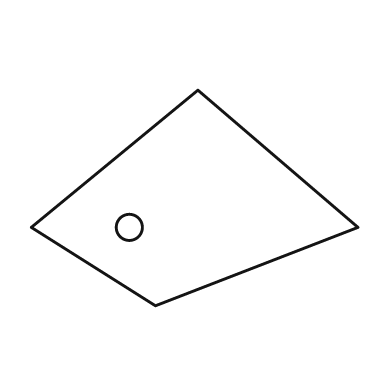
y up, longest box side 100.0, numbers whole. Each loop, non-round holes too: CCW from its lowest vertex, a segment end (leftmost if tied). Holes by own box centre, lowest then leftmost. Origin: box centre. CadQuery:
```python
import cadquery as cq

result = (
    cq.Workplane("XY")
    .moveTo(-12.0, -33.0)
    .lineTo(50.0, -9.0)
    .lineTo(1.0, 33.0)
    .lineTo(-50.0, -9.0)
    .close()
    .moveTo(-20.0, -9.0)
    .circle(4.0)
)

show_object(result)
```